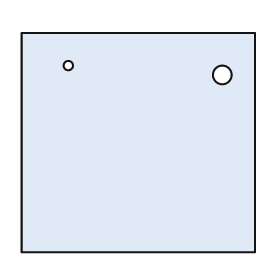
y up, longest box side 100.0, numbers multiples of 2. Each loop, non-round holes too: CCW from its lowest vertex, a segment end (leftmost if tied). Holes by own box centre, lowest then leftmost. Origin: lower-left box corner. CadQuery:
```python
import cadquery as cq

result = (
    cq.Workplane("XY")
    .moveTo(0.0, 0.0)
    .lineTo(100.0, 0.0)
    .lineTo(100.0, 94.0)
    .lineTo(0.0, 94.0)
    .close()
    .moveTo(86.0, 76.0)
    .circle(4.0)
    .moveTo(20.0, 80.0)
    .circle(2.0)
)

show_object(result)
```